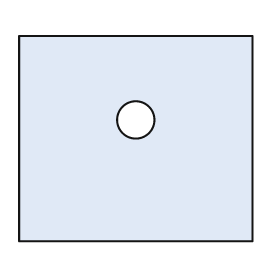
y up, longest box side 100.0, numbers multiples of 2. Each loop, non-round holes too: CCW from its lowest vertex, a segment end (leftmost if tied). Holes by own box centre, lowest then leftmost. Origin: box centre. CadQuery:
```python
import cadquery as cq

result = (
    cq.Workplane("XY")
    .moveTo(-50.0, -44.0)
    .lineTo(50.0, -44.0)
    .lineTo(50.0, 44.0)
    .lineTo(-50.0, 44.0)
    .close()
    .moveTo(0.0, 8.0)
    .circle(8.0)
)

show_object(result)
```